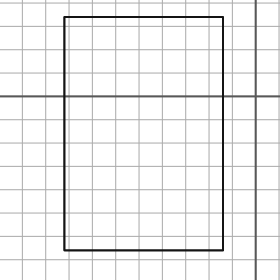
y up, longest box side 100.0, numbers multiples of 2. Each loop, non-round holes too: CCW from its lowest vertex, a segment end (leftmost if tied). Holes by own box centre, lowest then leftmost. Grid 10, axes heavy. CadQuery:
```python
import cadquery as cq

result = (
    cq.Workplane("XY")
    .moveTo(-82.0, -66.0)
    .lineTo(-14.0, -66.0)
    .lineTo(-14.0, 34.0)
    .lineTo(-82.0, 34.0)
    .close()
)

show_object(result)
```